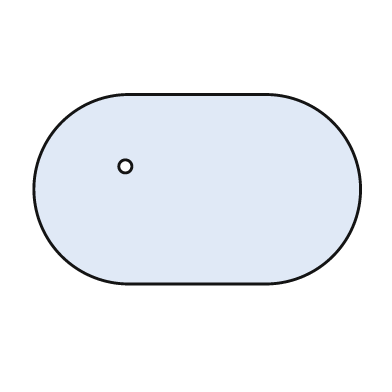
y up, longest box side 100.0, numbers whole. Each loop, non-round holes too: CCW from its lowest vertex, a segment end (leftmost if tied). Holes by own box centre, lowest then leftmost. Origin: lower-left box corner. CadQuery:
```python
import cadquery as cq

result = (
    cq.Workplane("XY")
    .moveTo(29.0, 0.0)
    .lineTo(71.0, 0.0)
    .threePointArc((100.0, 29.0), (71.0, 58.0))
    .lineTo(29.0, 58.0)
    .threePointArc((0.0, 29.0), (29.0, 0.0))
    .close()
    .moveTo(28.0, 36.0)
    .circle(2.0)
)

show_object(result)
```